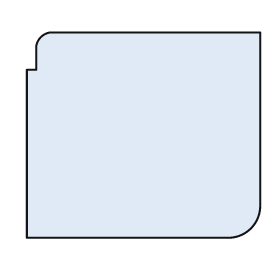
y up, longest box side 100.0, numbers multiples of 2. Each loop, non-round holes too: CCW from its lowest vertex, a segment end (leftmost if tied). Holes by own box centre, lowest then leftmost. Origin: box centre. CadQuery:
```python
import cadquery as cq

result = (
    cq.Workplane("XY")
    .moveTo(-50.0, -44.0)
    .lineTo(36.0, -44.0)
    .threePointArc((46.0, -40.0), (50.0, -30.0))
    .lineTo(50.0, 44.0)
    .lineTo(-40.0, 44.0)
    .threePointArc((-44.0, 42.0), (-46.0, 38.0))
    .lineTo(-46.0, 28.0)
    .lineTo(-50.0, 28.0)
    .close()
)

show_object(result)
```